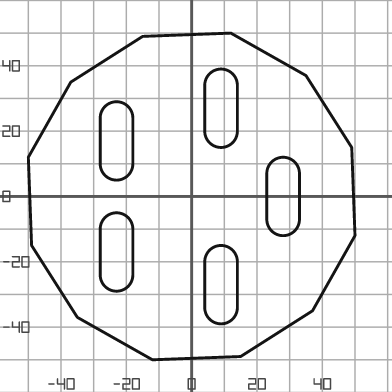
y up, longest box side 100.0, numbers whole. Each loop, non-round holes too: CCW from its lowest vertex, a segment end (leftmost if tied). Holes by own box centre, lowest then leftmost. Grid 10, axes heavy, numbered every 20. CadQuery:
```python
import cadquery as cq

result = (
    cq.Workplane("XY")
    .moveTo(-12.0, -50.0)
    .lineTo(15.0, -49.0)
    .lineTo(37.0, -35.0)
    .lineTo(50.0, -12.0)
    .lineTo(49.0, 15.0)
    .lineTo(35.0, 37.0)
    .lineTo(12.0, 50.0)
    .lineTo(-15.0, 49.0)
    .lineTo(-37.0, 35.0)
    .lineTo(-50.0, 12.0)
    .lineTo(-49.0, -15.0)
    .lineTo(-35.0, -37.0)
    .close()
    .moveTo(4.0, -34.0)
    .threePointArc((9.0, -39.0), (14.0, -34.0))
    .lineTo(14.0, -20.0)
    .threePointArc((9.0, -15.0), (4.0, -20.0))
    .close()
    .moveTo(-28.0, -24.0)
    .threePointArc((-23.0, -29.0), (-18.0, -24.0))
    .lineTo(-18.0, -10.0)
    .threePointArc((-23.0, -5.0), (-28.0, -10.0))
    .close()
    .moveTo(23.0, -7.0)
    .threePointArc((28.0, -12.0), (33.0, -7.0))
    .lineTo(33.0, 7.0)
    .threePointArc((28.0, 12.0), (23.0, 7.0))
    .close()
    .moveTo(-28.0, 10.0)
    .threePointArc((-23.0, 5.0), (-18.0, 10.0))
    .lineTo(-18.0, 24.0)
    .threePointArc((-23.0, 29.0), (-28.0, 24.0))
    .close()
    .moveTo(4.0, 20.0)
    .threePointArc((9.0, 15.0), (14.0, 20.0))
    .lineTo(14.0, 34.0)
    .threePointArc((9.0, 39.0), (4.0, 34.0))
    .close()
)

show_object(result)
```